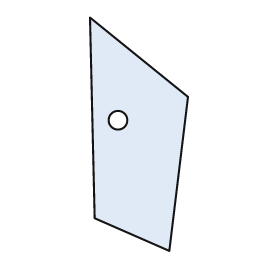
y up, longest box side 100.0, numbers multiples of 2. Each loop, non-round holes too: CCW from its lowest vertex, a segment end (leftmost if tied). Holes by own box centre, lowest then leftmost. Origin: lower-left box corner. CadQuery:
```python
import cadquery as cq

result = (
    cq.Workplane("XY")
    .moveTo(34.0, 0.0)
    .lineTo(42.0, 66.0)
    .lineTo(0.0, 100.0)
    .lineTo(2.0, 14.0)
    .close()
    .moveTo(12.0, 56.0)
    .circle(4.0)
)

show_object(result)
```